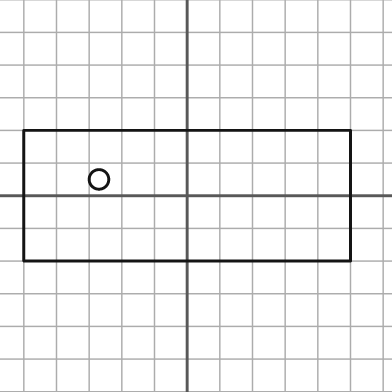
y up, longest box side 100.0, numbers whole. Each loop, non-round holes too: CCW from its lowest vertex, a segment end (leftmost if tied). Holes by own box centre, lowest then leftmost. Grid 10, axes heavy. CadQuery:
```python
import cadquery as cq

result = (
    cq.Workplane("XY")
    .moveTo(-50.0, -20.0)
    .lineTo(50.0, -20.0)
    .lineTo(50.0, 20.0)
    .lineTo(-50.0, 20.0)
    .close()
    .moveTo(-27.0, 5.0)
    .circle(3.0)
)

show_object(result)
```